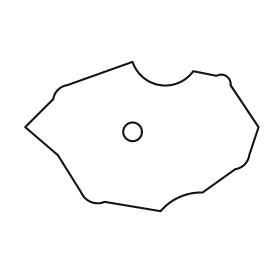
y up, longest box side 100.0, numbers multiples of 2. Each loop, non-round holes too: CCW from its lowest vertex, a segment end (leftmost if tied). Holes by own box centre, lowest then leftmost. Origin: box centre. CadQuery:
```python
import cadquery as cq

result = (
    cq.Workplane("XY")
    .moveTo(8.0, -32.0)
    .threePointArc((16.0, -26.0), (26.0, -24.0))
    .lineTo(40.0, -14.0)
    .threePointArc((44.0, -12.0), (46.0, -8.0))
    .lineTo(50.0, 4.0)
    .lineTo(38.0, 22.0)
    .threePointArc((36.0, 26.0), (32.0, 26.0))
    .lineTo(22.0, 28.0)
    .threePointArc((8.0, 22.0), (-4.0, 32.0))
    .lineTo(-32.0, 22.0)
    .threePointArc((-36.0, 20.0), (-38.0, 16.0))
    .lineTo(-50.0, 4.0)
    .lineTo(-36.0, -8.0)
    .lineTo(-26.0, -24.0)
    .threePointArc((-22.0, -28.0), (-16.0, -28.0))
    .close()
    .moveTo(-4.0, 2.0)
    .circle(4.0)
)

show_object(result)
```